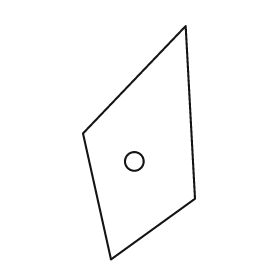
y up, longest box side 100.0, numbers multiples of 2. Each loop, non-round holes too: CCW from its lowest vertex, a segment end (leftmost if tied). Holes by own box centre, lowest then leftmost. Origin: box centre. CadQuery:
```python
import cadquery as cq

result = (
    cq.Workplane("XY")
    .moveTo(-12.0, -50.0)
    .lineTo(24.0, -24.0)
    .lineTo(20.0, 50.0)
    .lineTo(-24.0, 4.0)
    .close()
    .moveTo(-2.0, -8.0)
    .circle(4.0)
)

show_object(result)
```